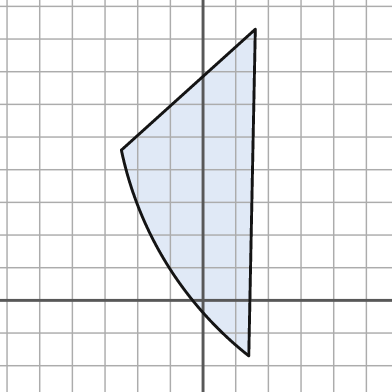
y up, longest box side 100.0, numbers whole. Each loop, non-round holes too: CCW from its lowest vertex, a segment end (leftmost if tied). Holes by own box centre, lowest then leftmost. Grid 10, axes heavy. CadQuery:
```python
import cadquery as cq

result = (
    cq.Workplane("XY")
    .moveTo(14.0, -17.0)
    .lineTo(16.0, 83.0)
    .lineTo(-25.0, 46.0)
    .threePointArc((-11.0, 11.0), (14.0, -17.0))
    .close()
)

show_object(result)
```